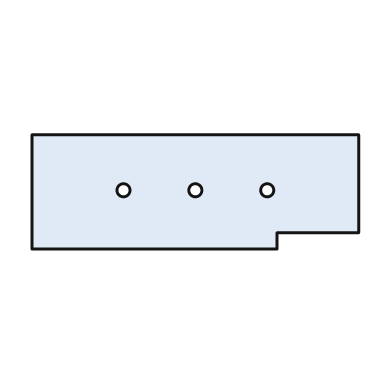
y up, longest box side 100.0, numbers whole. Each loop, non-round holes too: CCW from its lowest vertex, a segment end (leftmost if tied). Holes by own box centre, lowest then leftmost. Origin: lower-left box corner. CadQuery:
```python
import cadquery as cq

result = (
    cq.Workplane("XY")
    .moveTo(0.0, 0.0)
    .lineTo(75.0, 0.0)
    .lineTo(75.0, 5.0)
    .lineTo(100.0, 5.0)
    .lineTo(100.0, 35.0)
    .lineTo(0.0, 35.0)
    .close()
    .moveTo(28.0, 18.0)
    .circle(2.0)
    .moveTo(50.0, 18.0)
    .circle(2.0)
    .moveTo(72.0, 18.0)
    .circle(2.0)
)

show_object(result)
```